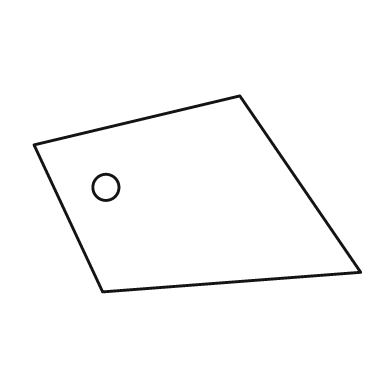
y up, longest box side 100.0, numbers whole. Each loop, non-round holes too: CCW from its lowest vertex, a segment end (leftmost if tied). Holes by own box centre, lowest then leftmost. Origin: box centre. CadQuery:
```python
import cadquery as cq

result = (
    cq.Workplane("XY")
    .moveTo(-29.0, -30.0)
    .lineTo(50.0, -24.0)
    .lineTo(13.0, 30.0)
    .lineTo(-50.0, 15.0)
    .close()
    .moveTo(-28.0, 2.0)
    .circle(4.0)
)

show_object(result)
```